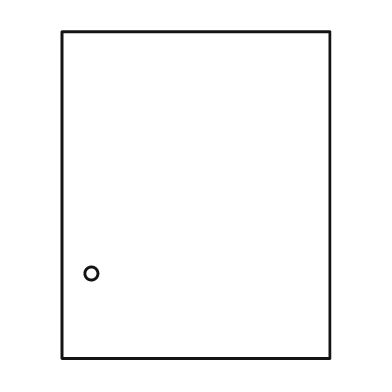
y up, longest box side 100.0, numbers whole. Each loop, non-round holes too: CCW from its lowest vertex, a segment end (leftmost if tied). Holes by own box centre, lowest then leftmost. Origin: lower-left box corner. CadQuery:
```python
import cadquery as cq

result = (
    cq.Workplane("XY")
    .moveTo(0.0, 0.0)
    .lineTo(82.0, 0.0)
    .lineTo(82.0, 100.0)
    .lineTo(0.0, 100.0)
    .close()
    .moveTo(9.0, 26.0)
    .circle(2.0)
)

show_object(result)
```